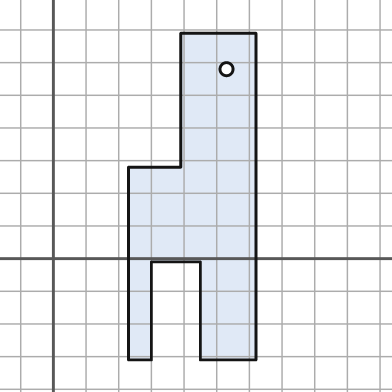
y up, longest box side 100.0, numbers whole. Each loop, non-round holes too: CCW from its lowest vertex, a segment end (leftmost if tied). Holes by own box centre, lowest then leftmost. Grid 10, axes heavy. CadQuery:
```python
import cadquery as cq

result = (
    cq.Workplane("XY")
    .moveTo(23.0, -31.0)
    .lineTo(30.0, -31.0)
    .lineTo(30.0, -1.0)
    .lineTo(45.0, -1.0)
    .lineTo(45.0, -31.0)
    .lineTo(62.0, -31.0)
    .lineTo(62.0, 69.0)
    .lineTo(39.0, 69.0)
    .lineTo(39.0, 28.0)
    .lineTo(23.0, 28.0)
    .close()
    .moveTo(53.0, 58.0)
    .circle(2.0)
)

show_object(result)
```